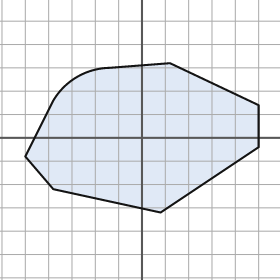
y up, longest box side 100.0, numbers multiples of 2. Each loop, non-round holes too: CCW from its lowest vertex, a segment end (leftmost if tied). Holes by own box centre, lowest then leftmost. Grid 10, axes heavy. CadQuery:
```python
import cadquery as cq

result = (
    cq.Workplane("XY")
    .moveTo(8.0, -32.0)
    .lineTo(50.0, -4.0)
    .lineTo(50.0, 14.0)
    .lineTo(12.0, 32.0)
    .lineTo(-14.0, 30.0)
    .threePointArc((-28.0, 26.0), (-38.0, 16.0))
    .lineTo(-50.0, -8.0)
    .lineTo(-38.0, -22.0)
    .close()
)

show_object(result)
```